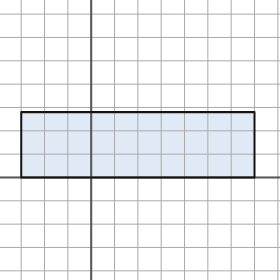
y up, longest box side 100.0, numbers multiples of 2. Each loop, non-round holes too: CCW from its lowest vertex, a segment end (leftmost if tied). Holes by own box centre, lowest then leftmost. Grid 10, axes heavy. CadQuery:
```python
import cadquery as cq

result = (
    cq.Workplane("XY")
    .moveTo(-30.0, 0.0)
    .lineTo(70.0, 0.0)
    .lineTo(70.0, 28.0)
    .lineTo(-30.0, 28.0)
    .close()
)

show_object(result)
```